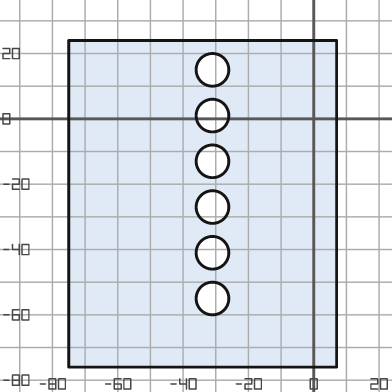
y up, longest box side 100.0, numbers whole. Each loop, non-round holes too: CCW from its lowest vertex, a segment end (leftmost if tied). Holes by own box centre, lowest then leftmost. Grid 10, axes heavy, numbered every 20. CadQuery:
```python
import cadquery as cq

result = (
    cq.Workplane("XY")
    .moveTo(-75.0, -76.0)
    .lineTo(7.0, -76.0)
    .lineTo(7.0, 24.0)
    .lineTo(-75.0, 24.0)
    .close()
    .moveTo(-31.0, -55.0)
    .circle(5.0)
    .moveTo(-31.0, -41.0)
    .circle(5.0)
    .moveTo(-31.0, -27.0)
    .circle(5.0)
    .moveTo(-31.0, -13.0)
    .circle(5.0)
    .moveTo(-31.0, 1.0)
    .circle(5.0)
    .moveTo(-31.0, 15.0)
    .circle(5.0)
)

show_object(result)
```